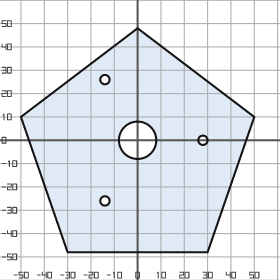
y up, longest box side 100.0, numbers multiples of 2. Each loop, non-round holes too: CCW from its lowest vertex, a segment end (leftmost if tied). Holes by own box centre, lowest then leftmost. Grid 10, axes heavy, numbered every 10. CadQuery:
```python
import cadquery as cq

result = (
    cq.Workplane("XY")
    .moveTo(-30.0, -48.0)
    .lineTo(30.0, -48.0)
    .lineTo(50.0, 10.0)
    .lineTo(0.0, 48.0)
    .lineTo(-50.0, 10.0)
    .close()
    .moveTo(-14.0, -26.0)
    .circle(2.0)
    .moveTo(0.0, 0.0)
    .circle(8.0)
    .moveTo(28.0, 0.0)
    .circle(2.0)
    .moveTo(-14.0, 26.0)
    .circle(2.0)
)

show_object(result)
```